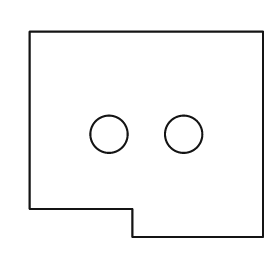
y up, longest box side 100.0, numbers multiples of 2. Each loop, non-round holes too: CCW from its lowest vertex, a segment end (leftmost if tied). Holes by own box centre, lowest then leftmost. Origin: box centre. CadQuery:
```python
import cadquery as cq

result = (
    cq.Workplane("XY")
    .moveTo(-6.0, -44.0)
    .lineTo(50.0, -44.0)
    .lineTo(50.0, 44.0)
    .lineTo(-50.0, 44.0)
    .lineTo(-50.0, -32.0)
    .lineTo(-6.0, -32.0)
    .close()
    .moveTo(-16.0, 0.0)
    .circle(8.0)
    .moveTo(16.0, 0.0)
    .circle(8.0)
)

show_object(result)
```